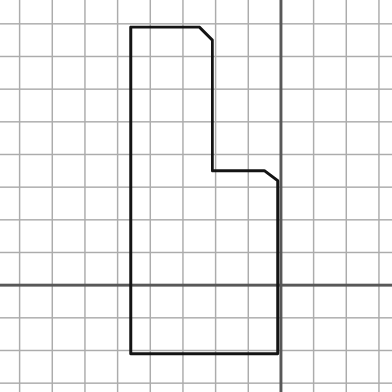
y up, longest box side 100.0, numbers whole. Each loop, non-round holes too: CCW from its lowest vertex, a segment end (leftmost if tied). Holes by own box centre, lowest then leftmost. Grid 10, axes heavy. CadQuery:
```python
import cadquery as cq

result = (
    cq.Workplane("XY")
    .moveTo(-46.0, -21.0)
    .lineTo(-1.0, -21.0)
    .lineTo(-1.0, 32.0)
    .lineTo(-5.0, 35.0)
    .lineTo(-21.0, 35.0)
    .lineTo(-21.0, 75.0)
    .lineTo(-25.0, 79.0)
    .lineTo(-46.0, 79.0)
    .close()
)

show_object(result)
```